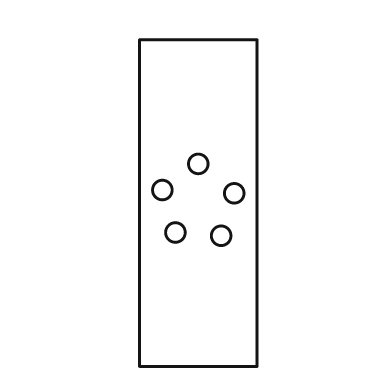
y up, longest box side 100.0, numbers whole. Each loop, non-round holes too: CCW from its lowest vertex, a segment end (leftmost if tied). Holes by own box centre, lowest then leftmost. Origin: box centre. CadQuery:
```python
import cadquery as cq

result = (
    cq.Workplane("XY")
    .moveTo(-18.0, -50.0)
    .lineTo(18.0, -50.0)
    .lineTo(18.0, 50.0)
    .lineTo(-18.0, 50.0)
    .close()
    .moveTo(7.0, -10.0)
    .circle(3.0)
    .moveTo(-7.0, -9.0)
    .circle(3.0)
    .moveTo(11.0, 3.0)
    .circle(3.0)
    .moveTo(-11.0, 4.0)
    .circle(3.0)
    .moveTo(0.0, 12.0)
    .circle(3.0)
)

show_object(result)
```